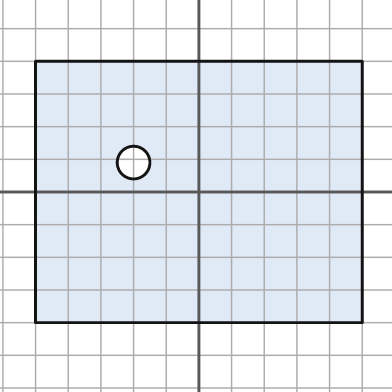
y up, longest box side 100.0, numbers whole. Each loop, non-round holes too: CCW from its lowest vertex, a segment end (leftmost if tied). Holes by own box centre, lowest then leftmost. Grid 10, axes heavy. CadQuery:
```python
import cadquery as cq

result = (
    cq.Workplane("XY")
    .moveTo(-50.0, -40.0)
    .lineTo(50.0, -40.0)
    .lineTo(50.0, 40.0)
    .lineTo(-50.0, 40.0)
    .close()
    .moveTo(-20.0, 9.0)
    .circle(5.0)
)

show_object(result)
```